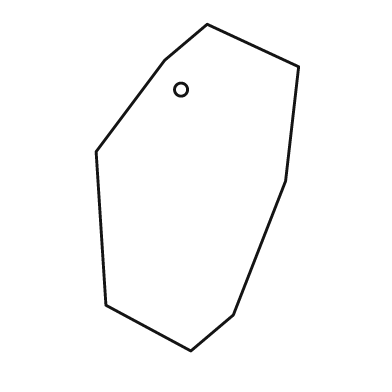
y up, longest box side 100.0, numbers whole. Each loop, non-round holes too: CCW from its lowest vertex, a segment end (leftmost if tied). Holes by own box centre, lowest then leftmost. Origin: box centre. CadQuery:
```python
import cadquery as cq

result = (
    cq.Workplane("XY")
    .moveTo(-2.0, -50.0)
    .lineTo(11.0, -39.0)
    .lineTo(27.0, 2.0)
    .lineTo(31.0, 37.0)
    .lineTo(3.0, 50.0)
    .lineTo(-10.0, 39.0)
    .lineTo(-31.0, 11.0)
    .lineTo(-28.0, -36.0)
    .close()
    .moveTo(-5.0, 30.0)
    .circle(2.0)
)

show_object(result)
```